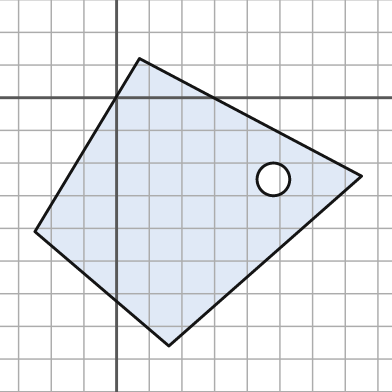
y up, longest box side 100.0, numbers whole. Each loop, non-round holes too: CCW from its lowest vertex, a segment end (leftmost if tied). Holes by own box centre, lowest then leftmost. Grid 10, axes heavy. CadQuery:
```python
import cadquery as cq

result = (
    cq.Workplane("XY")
    .moveTo(16.0, -76.0)
    .lineTo(75.0, -24.0)
    .lineTo(7.0, 12.0)
    .lineTo(-25.0, -41.0)
    .close()
    .moveTo(48.0, -25.0)
    .circle(5.0)
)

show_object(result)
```